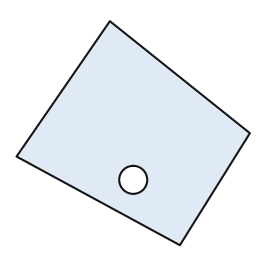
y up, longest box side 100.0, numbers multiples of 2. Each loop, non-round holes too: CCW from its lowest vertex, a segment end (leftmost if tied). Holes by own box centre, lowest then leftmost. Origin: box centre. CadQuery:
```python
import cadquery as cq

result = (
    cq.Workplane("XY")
    .moveTo(20.0, -48.0)
    .lineTo(50.0, 0.0)
    .lineTo(-10.0, 48.0)
    .lineTo(-50.0, -10.0)
    .close()
    .moveTo(0.0, -20.0)
    .circle(6.0)
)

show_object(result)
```